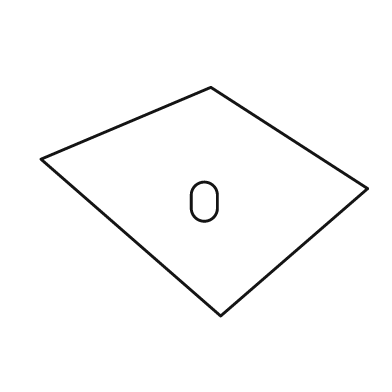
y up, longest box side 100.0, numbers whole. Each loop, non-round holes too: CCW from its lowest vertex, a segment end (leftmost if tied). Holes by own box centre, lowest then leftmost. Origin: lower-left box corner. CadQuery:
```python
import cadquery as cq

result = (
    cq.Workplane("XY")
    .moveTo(55.0, 0.0)
    .lineTo(100.0, 39.0)
    .lineTo(52.0, 70.0)
    .lineTo(0.0, 48.0)
    .close()
    .moveTo(46.0, 33.0)
    .threePointArc((50.0, 29.0), (54.0, 33.0))
    .lineTo(54.0, 37.0)
    .threePointArc((50.0, 41.0), (46.0, 37.0))
    .close()
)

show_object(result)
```